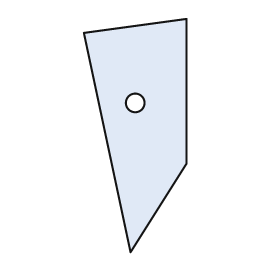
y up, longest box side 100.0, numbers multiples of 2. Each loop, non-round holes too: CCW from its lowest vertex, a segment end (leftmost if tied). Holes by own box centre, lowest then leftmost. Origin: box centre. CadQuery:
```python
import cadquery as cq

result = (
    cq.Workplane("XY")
    .moveTo(-2.0, -50.0)
    .lineTo(22.0, -12.0)
    .lineTo(22.0, 50.0)
    .lineTo(-22.0, 44.0)
    .close()
    .moveTo(0.0, 14.0)
    .circle(4.0)
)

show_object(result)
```